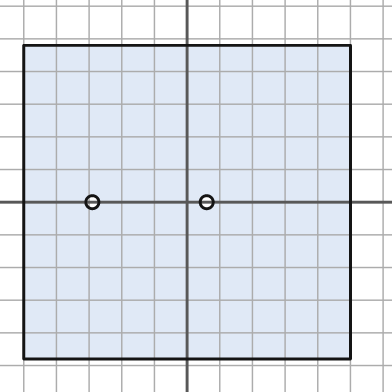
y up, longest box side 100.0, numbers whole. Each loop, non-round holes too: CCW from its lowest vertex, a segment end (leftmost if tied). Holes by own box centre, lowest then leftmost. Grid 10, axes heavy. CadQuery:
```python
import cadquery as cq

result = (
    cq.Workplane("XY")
    .moveTo(-50.0, -48.0)
    .lineTo(50.0, -48.0)
    .lineTo(50.0, 48.0)
    .lineTo(-50.0, 48.0)
    .close()
    .moveTo(-29.0, 0.0)
    .circle(2.0)
    .moveTo(6.0, 0.0)
    .circle(2.0)
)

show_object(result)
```